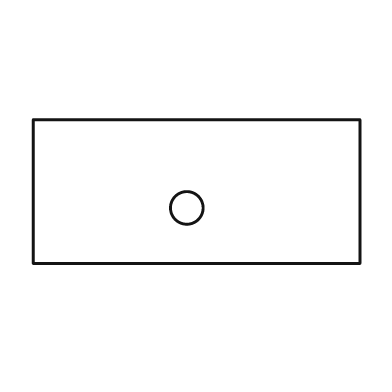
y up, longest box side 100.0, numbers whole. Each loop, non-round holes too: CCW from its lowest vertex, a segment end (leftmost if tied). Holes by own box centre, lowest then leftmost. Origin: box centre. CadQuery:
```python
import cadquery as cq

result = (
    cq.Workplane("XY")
    .moveTo(-50.0, -22.0)
    .lineTo(50.0, -22.0)
    .lineTo(50.0, 22.0)
    .lineTo(-50.0, 22.0)
    .close()
    .moveTo(-3.0, -5.0)
    .circle(5.0)
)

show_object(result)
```